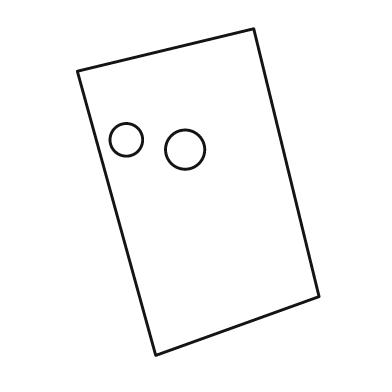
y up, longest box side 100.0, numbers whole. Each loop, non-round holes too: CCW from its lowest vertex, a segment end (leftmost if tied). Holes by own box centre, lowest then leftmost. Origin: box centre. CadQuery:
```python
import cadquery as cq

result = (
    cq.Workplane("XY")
    .moveTo(-13.0, -50.0)
    .lineTo(37.0, -32.0)
    .lineTo(17.0, 50.0)
    .lineTo(-37.0, 37.0)
    .close()
    .moveTo(-4.0, 13.0)
    .circle(6.0)
    .moveTo(-22.0, 16.0)
    .circle(5.0)
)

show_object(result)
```